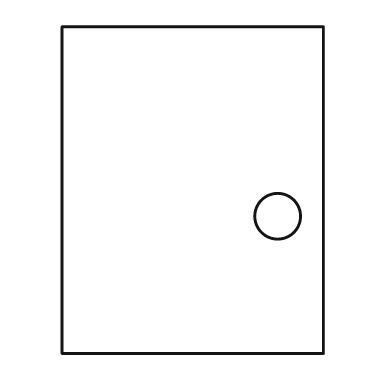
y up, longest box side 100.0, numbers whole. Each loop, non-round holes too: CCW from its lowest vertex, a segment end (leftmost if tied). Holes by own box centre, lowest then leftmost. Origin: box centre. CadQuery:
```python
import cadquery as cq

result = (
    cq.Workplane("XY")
    .moveTo(-40.0, -50.0)
    .lineTo(40.0, -50.0)
    .lineTo(40.0, 50.0)
    .lineTo(-40.0, 50.0)
    .close()
    .moveTo(26.0, -8.0)
    .circle(7.0)
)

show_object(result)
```